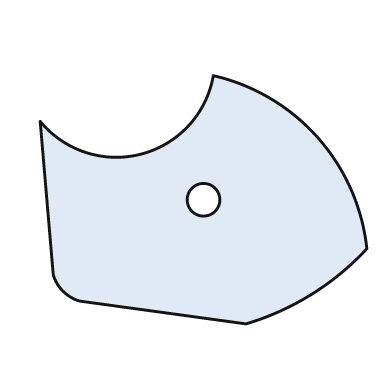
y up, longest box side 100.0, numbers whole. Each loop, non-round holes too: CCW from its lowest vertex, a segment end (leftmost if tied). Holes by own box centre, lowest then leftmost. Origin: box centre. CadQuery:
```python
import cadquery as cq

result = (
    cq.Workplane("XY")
    .moveTo(13.0, -38.0)
    .threePointArc((33.0, -29.0), (50.0, -15.0))
    .threePointArc((35.0, 19.0), (3.0, 38.0))
    .threePointArc((-19.0, 14.0), (-50.0, 24.0))
    .lineTo(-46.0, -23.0)
    .threePointArc((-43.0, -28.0), (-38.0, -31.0))
    .close()
    .moveTo(0.0, 0.0)
    .circle(5.0)
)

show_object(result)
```